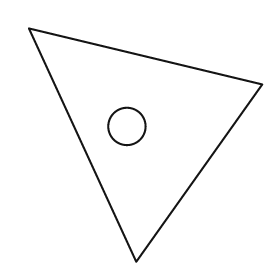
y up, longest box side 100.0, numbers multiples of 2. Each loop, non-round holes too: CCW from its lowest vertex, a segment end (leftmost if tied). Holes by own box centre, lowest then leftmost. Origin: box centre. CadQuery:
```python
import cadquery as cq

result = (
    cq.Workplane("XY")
    .moveTo(-4.0, -50.0)
    .lineTo(50.0, 26.0)
    .lineTo(-50.0, 50.0)
    .close()
    .moveTo(-8.0, 8.0)
    .circle(8.0)
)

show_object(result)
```